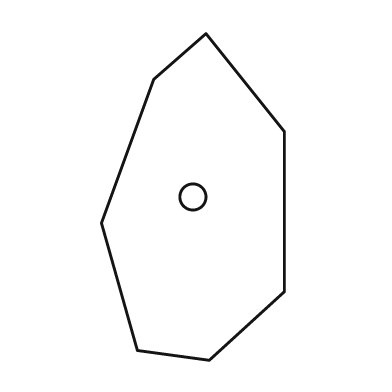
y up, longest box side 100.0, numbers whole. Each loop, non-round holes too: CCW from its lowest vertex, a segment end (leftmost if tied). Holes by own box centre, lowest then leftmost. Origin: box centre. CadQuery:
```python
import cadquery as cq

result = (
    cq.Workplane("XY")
    .moveTo(5.0, -50.0)
    .lineTo(28.0, -29.0)
    .lineTo(28.0, 20.0)
    .lineTo(4.0, 50.0)
    .lineTo(-12.0, 36.0)
    .lineTo(-28.0, -8.0)
    .lineTo(-17.0, -47.0)
    .close()
    .moveTo(0.0, 0.0)
    .circle(4.0)
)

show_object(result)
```